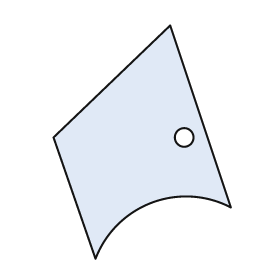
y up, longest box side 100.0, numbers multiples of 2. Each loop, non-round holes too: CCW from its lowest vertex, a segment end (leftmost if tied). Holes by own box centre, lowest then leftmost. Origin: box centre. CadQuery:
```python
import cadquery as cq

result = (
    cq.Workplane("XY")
    .moveTo(-20.0, -50.0)
    .threePointArc((4.0, -26.0), (38.0, -28.0))
    .lineTo(12.0, 50.0)
    .lineTo(-38.0, 2.0)
    .close()
    .moveTo(18.0, 2.0)
    .circle(4.0)
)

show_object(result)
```